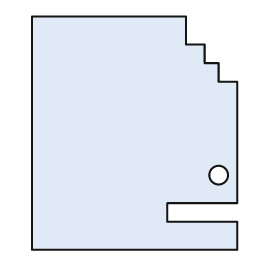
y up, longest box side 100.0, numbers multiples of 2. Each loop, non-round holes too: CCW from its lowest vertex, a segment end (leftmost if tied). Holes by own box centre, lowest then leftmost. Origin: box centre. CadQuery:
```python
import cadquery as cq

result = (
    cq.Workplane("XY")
    .moveTo(-44.0, -50.0)
    .lineTo(44.0, -50.0)
    .lineTo(44.0, -38.0)
    .lineTo(14.0, -38.0)
    .lineTo(14.0, -30.0)
    .lineTo(44.0, -30.0)
    .lineTo(44.0, 22.0)
    .lineTo(36.0, 22.0)
    .lineTo(36.0, 30.0)
    .lineTo(30.0, 30.0)
    .lineTo(30.0, 38.0)
    .lineTo(22.0, 38.0)
    .lineTo(22.0, 50.0)
    .lineTo(-44.0, 50.0)
    .close()
    .moveTo(36.0, -18.0)
    .circle(4.0)
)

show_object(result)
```